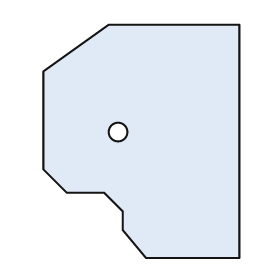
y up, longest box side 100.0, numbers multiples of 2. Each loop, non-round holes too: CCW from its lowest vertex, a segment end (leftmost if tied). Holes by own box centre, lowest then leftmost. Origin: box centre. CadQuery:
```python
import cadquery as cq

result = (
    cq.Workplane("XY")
    .moveTo(2.0, -50.0)
    .lineTo(42.0, -50.0)
    .lineTo(42.0, 50.0)
    .lineTo(-14.0, 50.0)
    .lineTo(-42.0, 30.0)
    .lineTo(-42.0, -12.0)
    .lineTo(-32.0, -22.0)
    .lineTo(-16.0, -22.0)
    .lineTo(-8.0, -30.0)
    .lineTo(-8.0, -38.0)
    .close()
    .moveTo(-10.0, 4.0)
    .circle(4.0)
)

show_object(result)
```